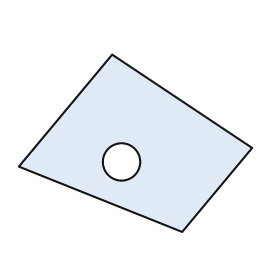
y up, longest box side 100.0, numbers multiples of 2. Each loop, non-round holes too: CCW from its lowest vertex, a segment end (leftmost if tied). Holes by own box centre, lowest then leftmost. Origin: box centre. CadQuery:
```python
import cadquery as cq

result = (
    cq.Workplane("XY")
    .moveTo(20.0, -38.0)
    .lineTo(50.0, -2.0)
    .lineTo(-10.0, 38.0)
    .lineTo(-50.0, -10.0)
    .close()
    .moveTo(-6.0, -8.0)
    .circle(8.0)
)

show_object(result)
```